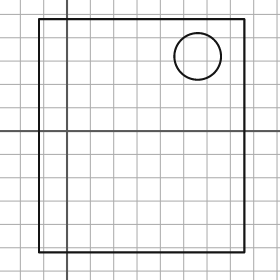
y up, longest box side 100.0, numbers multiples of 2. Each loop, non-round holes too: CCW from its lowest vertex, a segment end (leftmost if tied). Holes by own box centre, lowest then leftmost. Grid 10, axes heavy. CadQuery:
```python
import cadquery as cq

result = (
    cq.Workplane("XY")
    .moveTo(-12.0, -52.0)
    .lineTo(76.0, -52.0)
    .lineTo(76.0, 48.0)
    .lineTo(-12.0, 48.0)
    .close()
    .moveTo(56.0, 32.0)
    .circle(10.0)
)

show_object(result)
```